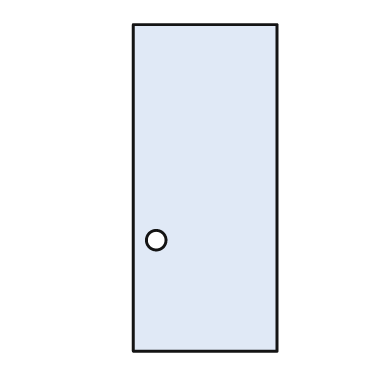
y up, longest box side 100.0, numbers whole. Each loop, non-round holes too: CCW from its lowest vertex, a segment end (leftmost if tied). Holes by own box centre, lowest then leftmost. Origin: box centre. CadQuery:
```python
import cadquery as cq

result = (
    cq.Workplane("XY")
    .moveTo(-22.0, -50.0)
    .lineTo(22.0, -50.0)
    .lineTo(22.0, 50.0)
    .lineTo(-22.0, 50.0)
    .close()
    .moveTo(-15.0, -16.0)
    .circle(3.0)
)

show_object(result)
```